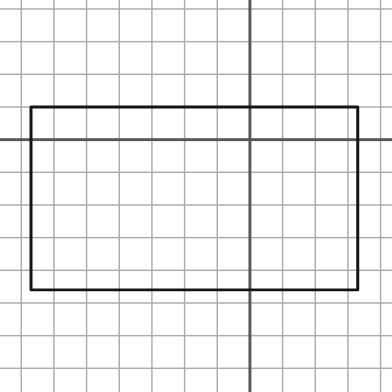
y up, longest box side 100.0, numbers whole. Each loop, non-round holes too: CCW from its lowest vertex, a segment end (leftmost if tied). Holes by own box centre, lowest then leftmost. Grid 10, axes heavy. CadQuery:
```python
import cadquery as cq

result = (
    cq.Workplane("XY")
    .moveTo(-67.0, -46.0)
    .lineTo(33.0, -46.0)
    .lineTo(33.0, 10.0)
    .lineTo(-67.0, 10.0)
    .close()
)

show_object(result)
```